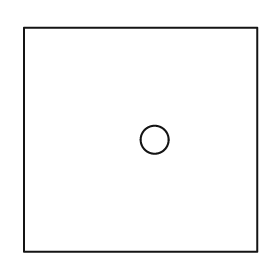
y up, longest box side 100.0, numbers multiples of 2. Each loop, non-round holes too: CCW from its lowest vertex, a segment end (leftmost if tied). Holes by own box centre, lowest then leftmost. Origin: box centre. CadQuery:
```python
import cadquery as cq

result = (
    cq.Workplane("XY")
    .moveTo(-50.0, -48.0)
    .lineTo(50.0, -48.0)
    .lineTo(50.0, 48.0)
    .lineTo(-50.0, 48.0)
    .close()
    .moveTo(6.0, 0.0)
    .circle(6.0)
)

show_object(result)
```